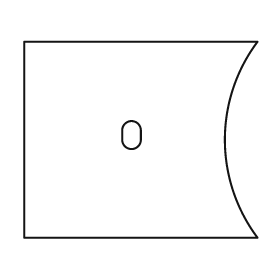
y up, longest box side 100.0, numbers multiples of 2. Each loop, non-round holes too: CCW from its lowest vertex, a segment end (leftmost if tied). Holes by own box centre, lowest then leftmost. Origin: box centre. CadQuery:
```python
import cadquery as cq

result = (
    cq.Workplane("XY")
    .moveTo(-50.0, -42.0)
    .lineTo(50.0, -42.0)
    .threePointArc((36.0, 0.0), (50.0, 42.0))
    .lineTo(-50.0, 42.0)
    .close()
    .moveTo(-8.0, 0.0)
    .threePointArc((-4.0, -4.0), (0.0, 0.0))
    .lineTo(0.0, 4.0)
    .threePointArc((-4.0, 8.0), (-8.0, 4.0))
    .close()
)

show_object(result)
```